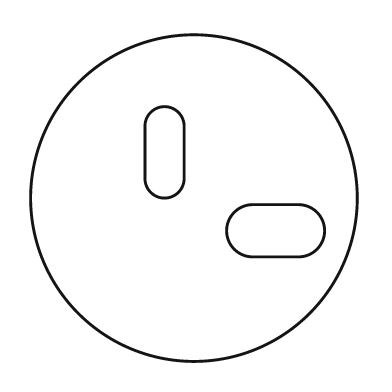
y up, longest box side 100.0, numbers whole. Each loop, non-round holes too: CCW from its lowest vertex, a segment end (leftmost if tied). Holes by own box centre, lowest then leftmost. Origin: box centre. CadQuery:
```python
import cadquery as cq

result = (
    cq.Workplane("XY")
    .moveTo(0.0, 0.0)
    .circle(50.0)
    .moveTo(18.0, -18.0)
    .lineTo(32.0, -18.0)
    .threePointArc((40.0, -10.0), (32.0, -2.0))
    .lineTo(18.0, -2.0)
    .threePointArc((10.0, -10.0), (18.0, -18.0))
    .close()
    .moveTo(-15.0, 6.0)
    .threePointArc((-9.0, 0.0), (-3.0, 6.0))
    .lineTo(-3.0, 22.0)
    .threePointArc((-9.0, 28.0), (-15.0, 22.0))
    .close()
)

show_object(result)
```